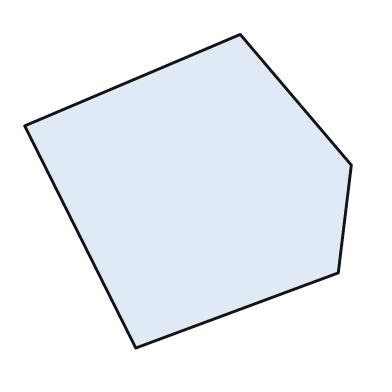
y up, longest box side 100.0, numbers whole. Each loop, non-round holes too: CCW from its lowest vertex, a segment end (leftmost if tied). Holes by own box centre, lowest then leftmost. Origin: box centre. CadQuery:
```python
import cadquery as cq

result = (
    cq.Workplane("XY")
    .moveTo(-16.0, -48.0)
    .lineTo(46.0, -25.0)
    .lineTo(50.0, 8.0)
    .lineTo(16.0, 48.0)
    .lineTo(-50.0, 20.0)
    .close()
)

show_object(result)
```